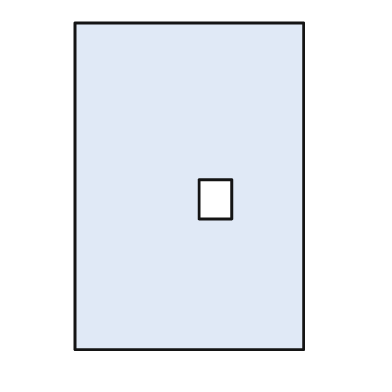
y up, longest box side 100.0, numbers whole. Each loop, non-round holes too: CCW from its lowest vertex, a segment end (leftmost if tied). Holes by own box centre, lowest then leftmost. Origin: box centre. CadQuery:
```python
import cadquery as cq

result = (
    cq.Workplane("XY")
    .moveTo(-35.0, -50.0)
    .lineTo(35.0, -50.0)
    .lineTo(35.0, 50.0)
    .lineTo(-35.0, 50.0)
    .close()
    .moveTo(3.0, -10.0)
    .lineTo(13.0, -10.0)
    .lineTo(13.0, 2.0)
    .lineTo(3.0, 2.0)
    .close()
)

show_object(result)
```